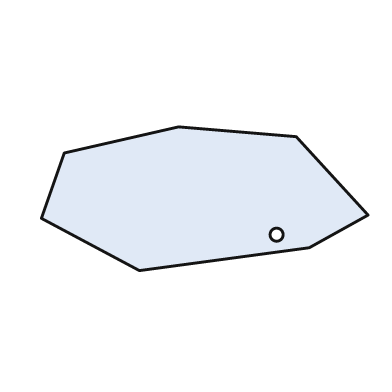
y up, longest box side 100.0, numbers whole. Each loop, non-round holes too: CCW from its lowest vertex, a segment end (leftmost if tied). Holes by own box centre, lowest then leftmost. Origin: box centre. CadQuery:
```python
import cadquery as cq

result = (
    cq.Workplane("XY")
    .moveTo(-20.0, -22.0)
    .lineTo(32.0, -15.0)
    .lineTo(50.0, -5.0)
    .lineTo(28.0, 19.0)
    .lineTo(-8.0, 22.0)
    .lineTo(-43.0, 14.0)
    .lineTo(-50.0, -6.0)
    .close()
    .moveTo(22.0, -11.0)
    .circle(2.0)
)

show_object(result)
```